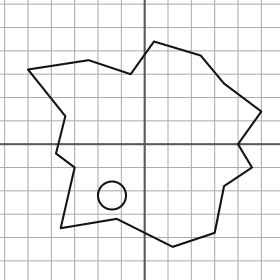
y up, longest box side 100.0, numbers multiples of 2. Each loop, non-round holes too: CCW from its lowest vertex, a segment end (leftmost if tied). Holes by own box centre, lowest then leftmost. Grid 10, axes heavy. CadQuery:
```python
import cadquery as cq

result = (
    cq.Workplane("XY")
    .moveTo(12.0, -44.0)
    .lineTo(30.0, -38.0)
    .lineTo(34.0, -18.0)
    .lineTo(46.0, -10.0)
    .lineTo(40.0, 0.0)
    .lineTo(50.0, 14.0)
    .lineTo(34.0, 26.0)
    .lineTo(24.0, 38.0)
    .lineTo(4.0, 44.0)
    .lineTo(-6.0, 30.0)
    .lineTo(-24.0, 36.0)
    .lineTo(-50.0, 32.0)
    .lineTo(-34.0, 12.0)
    .lineTo(-38.0, -4.0)
    .lineTo(-30.0, -10.0)
    .lineTo(-36.0, -36.0)
    .lineTo(-12.0, -32.0)
    .close()
    .moveTo(-14.0, -22.0)
    .circle(6.0)
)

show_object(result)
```